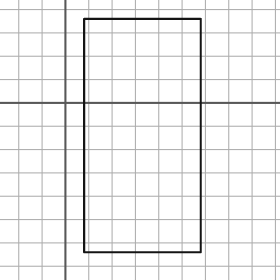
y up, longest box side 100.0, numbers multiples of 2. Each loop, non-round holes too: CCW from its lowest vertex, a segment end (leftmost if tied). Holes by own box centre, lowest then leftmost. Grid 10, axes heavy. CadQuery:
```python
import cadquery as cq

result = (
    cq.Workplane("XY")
    .moveTo(8.0, -64.0)
    .lineTo(58.0, -64.0)
    .lineTo(58.0, 36.0)
    .lineTo(8.0, 36.0)
    .close()
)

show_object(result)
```